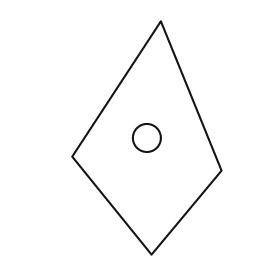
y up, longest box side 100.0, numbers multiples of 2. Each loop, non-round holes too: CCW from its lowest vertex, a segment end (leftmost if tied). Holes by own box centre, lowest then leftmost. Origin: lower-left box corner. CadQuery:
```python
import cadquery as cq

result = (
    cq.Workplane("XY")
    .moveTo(34.0, 0.0)
    .lineTo(64.0, 36.0)
    .lineTo(38.0, 100.0)
    .lineTo(0.0, 42.0)
    .close()
    .moveTo(32.0, 50.0)
    .circle(6.0)
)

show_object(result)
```